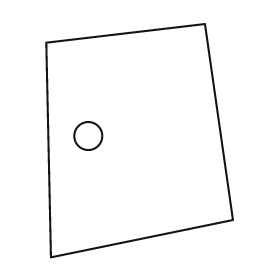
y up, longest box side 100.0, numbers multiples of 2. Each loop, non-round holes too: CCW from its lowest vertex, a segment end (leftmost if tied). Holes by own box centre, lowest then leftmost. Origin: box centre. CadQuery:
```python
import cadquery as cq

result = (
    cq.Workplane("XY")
    .moveTo(-38.0, -50.0)
    .lineTo(40.0, -34.0)
    .lineTo(28.0, 50.0)
    .lineTo(-40.0, 42.0)
    .close()
    .moveTo(-22.0, 2.0)
    .circle(6.0)
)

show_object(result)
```